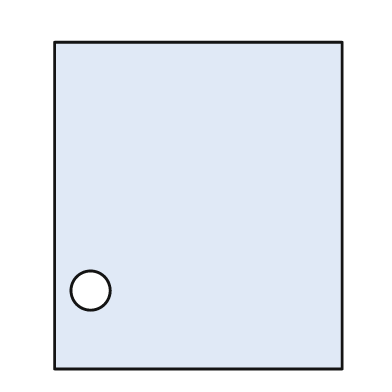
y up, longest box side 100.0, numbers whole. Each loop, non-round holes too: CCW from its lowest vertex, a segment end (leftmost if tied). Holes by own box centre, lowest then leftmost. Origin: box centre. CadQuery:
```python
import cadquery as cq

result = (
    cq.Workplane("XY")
    .moveTo(-44.0, -50.0)
    .lineTo(44.0, -50.0)
    .lineTo(44.0, 50.0)
    .lineTo(-44.0, 50.0)
    .close()
    .moveTo(-33.0, -26.0)
    .circle(6.0)
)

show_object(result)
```